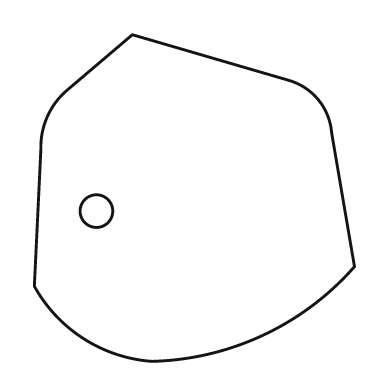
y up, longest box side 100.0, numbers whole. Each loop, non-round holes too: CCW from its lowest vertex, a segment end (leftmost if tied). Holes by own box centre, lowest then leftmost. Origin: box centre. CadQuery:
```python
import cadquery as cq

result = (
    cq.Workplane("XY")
    .moveTo(-13.0, -50.0)
    .threePointArc((21.0, -42.0), (49.0, -21.0))
    .lineTo(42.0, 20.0)
    .threePointArc((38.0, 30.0), (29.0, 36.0))
    .lineTo(-19.0, 50.0)
    .lineTo(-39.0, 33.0)
    .threePointArc((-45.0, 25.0), (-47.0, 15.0))
    .lineTo(-49.0, -27.0)
    .threePointArc((-34.0, -43.0), (-13.0, -50.0))
    .close()
    .moveTo(-30.0, -4.0)
    .circle(5.0)
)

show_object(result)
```